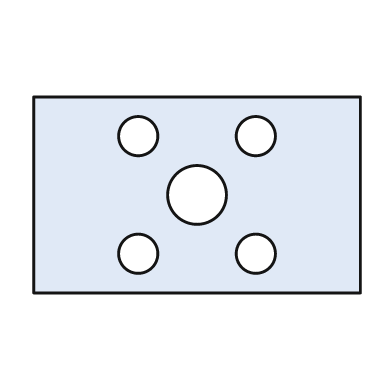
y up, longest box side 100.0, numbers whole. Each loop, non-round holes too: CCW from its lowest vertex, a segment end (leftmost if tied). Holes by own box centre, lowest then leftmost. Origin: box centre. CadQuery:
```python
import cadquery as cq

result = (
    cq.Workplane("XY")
    .moveTo(-50.0, -30.0)
    .lineTo(50.0, -30.0)
    .lineTo(50.0, 30.0)
    .lineTo(-50.0, 30.0)
    .close()
    .moveTo(-18.0, -18.0)
    .circle(6.0)
    .moveTo(18.0, -18.0)
    .circle(6.0)
    .moveTo(0.0, 0.0)
    .circle(9.0)
    .moveTo(-18.0, 18.0)
    .circle(6.0)
    .moveTo(18.0, 18.0)
    .circle(6.0)
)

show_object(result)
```